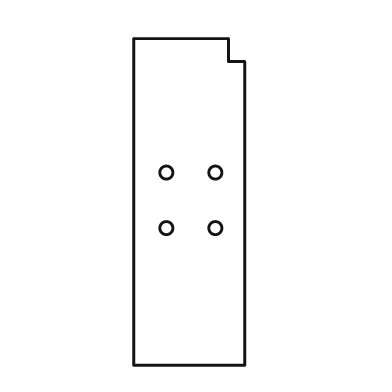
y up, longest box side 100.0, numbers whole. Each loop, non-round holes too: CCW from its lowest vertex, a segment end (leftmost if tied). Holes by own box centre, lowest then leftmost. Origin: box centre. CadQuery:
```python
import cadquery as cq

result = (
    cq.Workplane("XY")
    .moveTo(-17.0, -50.0)
    .lineTo(17.0, -50.0)
    .lineTo(17.0, 43.0)
    .lineTo(12.0, 43.0)
    .lineTo(12.0, 50.0)
    .lineTo(-17.0, 50.0)
    .close()
    .moveTo(-7.0, -8.0)
    .circle(2.0)
    .moveTo(8.0, -8.0)
    .circle(2.0)
    .moveTo(-7.0, 9.0)
    .circle(2.0)
    .moveTo(8.0, 9.0)
    .circle(2.0)
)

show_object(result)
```